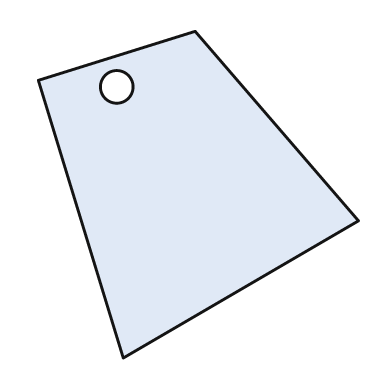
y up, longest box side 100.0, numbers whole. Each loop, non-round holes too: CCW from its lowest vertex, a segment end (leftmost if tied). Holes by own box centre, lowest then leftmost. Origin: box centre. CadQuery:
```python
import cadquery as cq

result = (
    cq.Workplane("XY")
    .moveTo(-23.0, -50.0)
    .lineTo(49.0, -8.0)
    .lineTo(-1.0, 50.0)
    .lineTo(-49.0, 35.0)
    .close()
    .moveTo(-25.0, 33.0)
    .circle(5.0)
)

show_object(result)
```